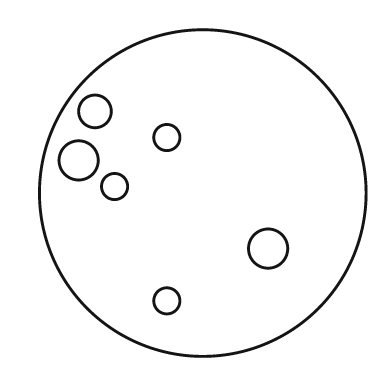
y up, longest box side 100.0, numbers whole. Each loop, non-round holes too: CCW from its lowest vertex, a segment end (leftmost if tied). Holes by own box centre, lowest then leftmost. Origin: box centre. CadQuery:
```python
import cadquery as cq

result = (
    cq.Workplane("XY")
    .moveTo(0.0, 0.0)
    .circle(50.0)
    .moveTo(-11.0, -33.0)
    .circle(4.0)
    .moveTo(20.0, -17.0)
    .circle(6.0)
    .moveTo(-27.0, 2.0)
    .circle(4.0)
    .moveTo(-38.0, 10.0)
    .circle(6.0)
    .moveTo(-11.0, 17.0)
    .circle(4.0)
    .moveTo(-33.0, 25.0)
    .circle(5.0)
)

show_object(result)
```